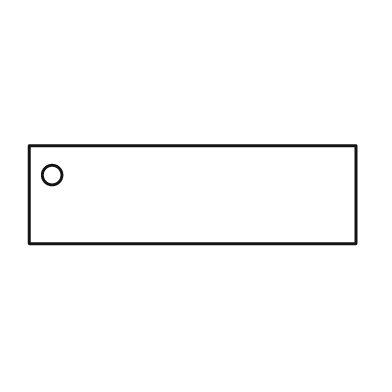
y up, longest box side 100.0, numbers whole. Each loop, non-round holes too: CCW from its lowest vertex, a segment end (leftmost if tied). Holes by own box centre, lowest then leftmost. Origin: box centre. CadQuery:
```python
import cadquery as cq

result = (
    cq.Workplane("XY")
    .moveTo(-50.0, -15.0)
    .lineTo(50.0, -15.0)
    .lineTo(50.0, 15.0)
    .lineTo(-50.0, 15.0)
    .close()
    .moveTo(-43.0, 6.0)
    .circle(3.0)
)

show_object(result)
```